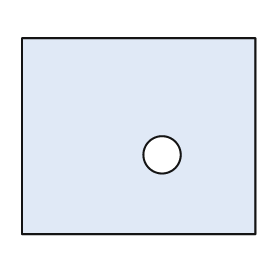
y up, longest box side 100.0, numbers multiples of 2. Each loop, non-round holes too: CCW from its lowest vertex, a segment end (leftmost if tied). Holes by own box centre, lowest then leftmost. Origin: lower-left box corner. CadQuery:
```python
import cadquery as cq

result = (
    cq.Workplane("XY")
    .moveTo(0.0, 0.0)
    .lineTo(100.0, 0.0)
    .lineTo(100.0, 84.0)
    .lineTo(0.0, 84.0)
    .close()
    .moveTo(60.0, 34.0)
    .circle(8.0)
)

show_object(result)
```